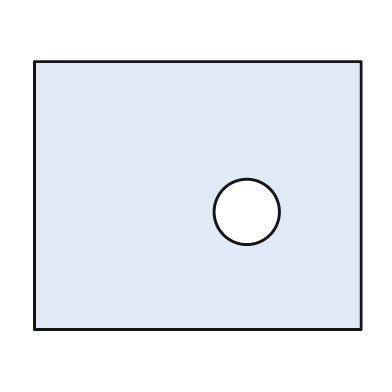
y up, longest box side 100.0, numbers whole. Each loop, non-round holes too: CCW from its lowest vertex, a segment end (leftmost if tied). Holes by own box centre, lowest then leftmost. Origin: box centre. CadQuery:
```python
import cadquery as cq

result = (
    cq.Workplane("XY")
    .moveTo(-50.0, -41.0)
    .lineTo(50.0, -41.0)
    .lineTo(50.0, 41.0)
    .lineTo(-50.0, 41.0)
    .close()
    .moveTo(15.0, -5.0)
    .circle(10.0)
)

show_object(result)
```